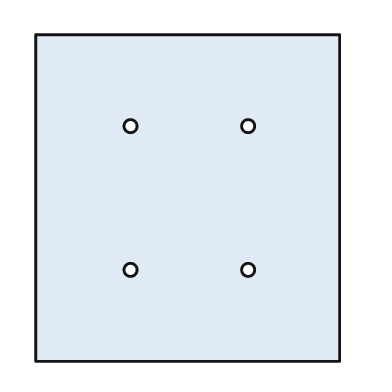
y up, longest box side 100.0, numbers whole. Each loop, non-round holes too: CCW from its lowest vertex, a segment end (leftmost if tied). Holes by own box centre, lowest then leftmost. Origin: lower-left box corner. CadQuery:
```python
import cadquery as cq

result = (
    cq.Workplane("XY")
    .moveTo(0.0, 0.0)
    .lineTo(93.0, 0.0)
    .lineTo(93.0, 100.0)
    .lineTo(0.0, 100.0)
    .close()
    .moveTo(29.0, 28.0)
    .circle(2.0)
    .moveTo(65.0, 28.0)
    .circle(2.0)
    .moveTo(29.0, 72.0)
    .circle(2.0)
    .moveTo(65.0, 72.0)
    .circle(2.0)
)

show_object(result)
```